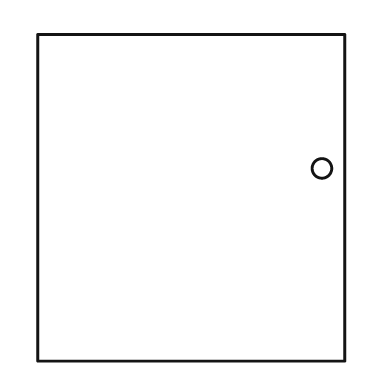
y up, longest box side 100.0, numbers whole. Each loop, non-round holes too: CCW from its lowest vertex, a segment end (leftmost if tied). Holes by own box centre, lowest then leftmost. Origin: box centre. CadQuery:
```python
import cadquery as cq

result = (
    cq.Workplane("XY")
    .moveTo(-47.0, -50.0)
    .lineTo(47.0, -50.0)
    .lineTo(47.0, 50.0)
    .lineTo(-47.0, 50.0)
    .close()
    .moveTo(40.0, 9.0)
    .circle(3.0)
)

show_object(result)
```